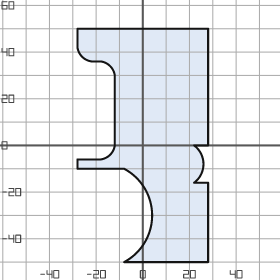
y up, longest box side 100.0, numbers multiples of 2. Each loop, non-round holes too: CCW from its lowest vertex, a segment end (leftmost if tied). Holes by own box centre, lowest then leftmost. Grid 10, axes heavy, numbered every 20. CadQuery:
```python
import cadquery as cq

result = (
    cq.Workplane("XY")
    .moveTo(-8.0, -50.0)
    .lineTo(28.0, -50.0)
    .lineTo(28.0, -16.0)
    .lineTo(22.0, -16.0)
    .threePointArc((26.0, -8.0), (22.0, 0.0))
    .lineTo(28.0, 0.0)
    .lineTo(28.0, 50.0)
    .lineTo(-28.0, 50.0)
    .lineTo(-28.0, 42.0)
    .threePointArc((-26.0, 38.0), (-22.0, 36.0))
    .lineTo(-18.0, 36.0)
    .threePointArc((-14.0, 34.0), (-12.0, 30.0))
    .lineTo(-12.0, 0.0)
    .threePointArc((-14.0, -4.0), (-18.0, -6.0))
    .lineTo(-28.0, -6.0)
    .lineTo(-28.0, -10.0)
    .lineTo(-8.0, -10.0)
    .threePointArc((4.0, -30.0), (-8.0, -50.0))
    .close()
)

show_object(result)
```